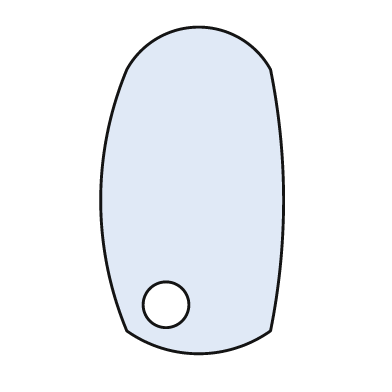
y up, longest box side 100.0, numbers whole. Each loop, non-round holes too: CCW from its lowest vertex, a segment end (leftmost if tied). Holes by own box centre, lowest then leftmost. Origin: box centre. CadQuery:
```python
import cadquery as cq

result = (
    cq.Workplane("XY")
    .moveTo(-20.0, -43.0)
    .threePointArc((2.0, -50.0), (24.0, -43.0))
    .threePointArc((28.0, -3.0), (24.0, 37.0))
    .threePointArc((2.0, 50.0), (-20.0, 37.0))
    .threePointArc((-28.0, -3.0), (-20.0, -43.0))
    .close()
    .moveTo(-8.0, -35.0)
    .circle(7.0)
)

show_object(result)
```